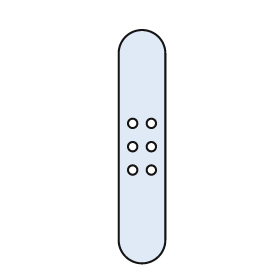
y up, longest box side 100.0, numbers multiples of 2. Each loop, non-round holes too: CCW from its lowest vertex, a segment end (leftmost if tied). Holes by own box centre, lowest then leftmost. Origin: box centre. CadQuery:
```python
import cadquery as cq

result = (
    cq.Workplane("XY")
    .moveTo(-10.0, -40.0)
    .threePointArc((0.0, -50.0), (10.0, -40.0))
    .lineTo(10.0, 40.0)
    .threePointArc((0.0, 50.0), (-10.0, 40.0))
    .close()
    .moveTo(-4.0, -10.0)
    .circle(2.0)
    .moveTo(4.0, -10.0)
    .circle(2.0)
    .moveTo(-4.0, 0.0)
    .circle(2.0)
    .moveTo(4.0, 0.0)
    .circle(2.0)
    .moveTo(-4.0, 10.0)
    .circle(2.0)
    .moveTo(4.0, 10.0)
    .circle(2.0)
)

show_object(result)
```